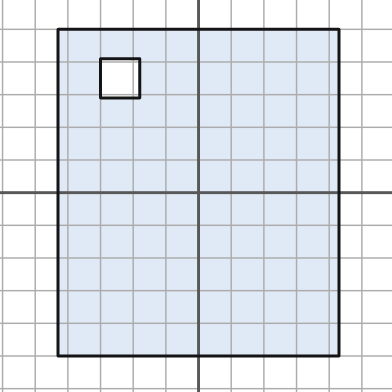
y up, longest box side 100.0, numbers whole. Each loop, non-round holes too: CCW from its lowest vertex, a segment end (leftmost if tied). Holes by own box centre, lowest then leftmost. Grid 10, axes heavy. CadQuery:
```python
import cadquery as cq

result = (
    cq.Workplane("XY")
    .moveTo(-43.0, -50.0)
    .lineTo(43.0, -50.0)
    .lineTo(43.0, 50.0)
    .lineTo(-43.0, 50.0)
    .close()
    .moveTo(-30.0, 29.0)
    .lineTo(-18.0, 29.0)
    .lineTo(-18.0, 41.0)
    .lineTo(-30.0, 41.0)
    .close()
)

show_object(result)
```